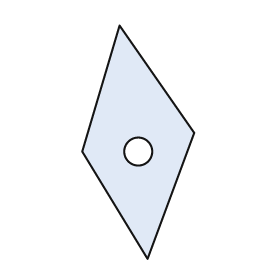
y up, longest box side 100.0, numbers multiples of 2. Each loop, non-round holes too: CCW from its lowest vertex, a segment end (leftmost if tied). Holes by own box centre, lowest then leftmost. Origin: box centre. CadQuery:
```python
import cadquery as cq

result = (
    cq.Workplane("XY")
    .moveTo(4.0, -50.0)
    .lineTo(24.0, 4.0)
    .lineTo(-8.0, 50.0)
    .lineTo(-24.0, -4.0)
    .close()
    .moveTo(0.0, -4.0)
    .circle(6.0)
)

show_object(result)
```